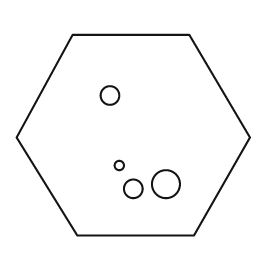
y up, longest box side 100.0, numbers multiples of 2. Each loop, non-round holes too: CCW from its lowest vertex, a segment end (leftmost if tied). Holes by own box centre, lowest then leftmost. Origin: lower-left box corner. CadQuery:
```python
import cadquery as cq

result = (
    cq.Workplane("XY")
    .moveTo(26.0, 0.0)
    .lineTo(76.0, 0.0)
    .lineTo(100.0, 42.0)
    .lineTo(74.0, 86.0)
    .lineTo(24.0, 86.0)
    .lineTo(0.0, 42.0)
    .close()
    .moveTo(50.0, 20.0)
    .circle(4.0)
    .moveTo(64.0, 22.0)
    .circle(6.0)
    .moveTo(44.0, 30.0)
    .circle(2.0)
    .moveTo(40.0, 60.0)
    .circle(4.0)
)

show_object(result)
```